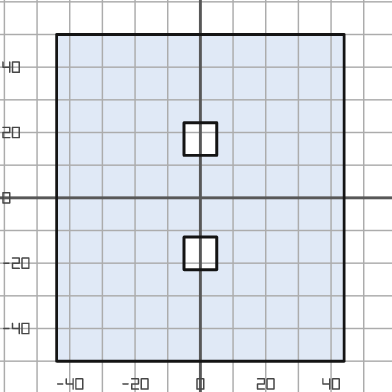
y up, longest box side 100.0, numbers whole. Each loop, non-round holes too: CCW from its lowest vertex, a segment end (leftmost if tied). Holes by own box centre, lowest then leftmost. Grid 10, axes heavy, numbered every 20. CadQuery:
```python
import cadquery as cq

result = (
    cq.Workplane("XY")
    .moveTo(-44.0, -50.0)
    .lineTo(44.0, -50.0)
    .lineTo(44.0, 50.0)
    .lineTo(-44.0, 50.0)
    .close()
    .moveTo(-5.0, -22.0)
    .lineTo(5.0, -22.0)
    .lineTo(5.0, -12.0)
    .lineTo(-5.0, -12.0)
    .close()
    .moveTo(-5.0, 13.0)
    .lineTo(5.0, 13.0)
    .lineTo(5.0, 23.0)
    .lineTo(-5.0, 23.0)
    .close()
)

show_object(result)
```